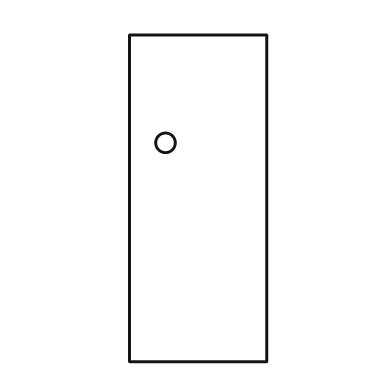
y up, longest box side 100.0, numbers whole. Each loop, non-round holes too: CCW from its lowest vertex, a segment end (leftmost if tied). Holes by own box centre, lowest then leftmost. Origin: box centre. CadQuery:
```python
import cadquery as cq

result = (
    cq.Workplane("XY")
    .moveTo(-21.0, -50.0)
    .lineTo(21.0, -50.0)
    .lineTo(21.0, 50.0)
    .lineTo(-21.0, 50.0)
    .close()
    .moveTo(-10.0, 17.0)
    .circle(3.0)
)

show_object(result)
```